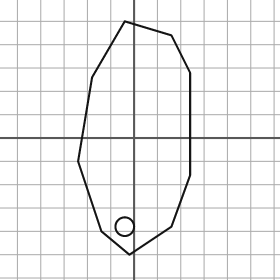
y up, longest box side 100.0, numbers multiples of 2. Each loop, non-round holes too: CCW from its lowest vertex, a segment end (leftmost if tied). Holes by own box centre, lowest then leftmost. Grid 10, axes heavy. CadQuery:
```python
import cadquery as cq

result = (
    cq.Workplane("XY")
    .moveTo(-2.0, -50.0)
    .lineTo(16.0, -38.0)
    .lineTo(24.0, -16.0)
    .lineTo(24.0, 28.0)
    .lineTo(16.0, 44.0)
    .lineTo(-4.0, 50.0)
    .lineTo(-18.0, 26.0)
    .lineTo(-24.0, -10.0)
    .lineTo(-14.0, -40.0)
    .close()
    .moveTo(-4.0, -38.0)
    .circle(4.0)
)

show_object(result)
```